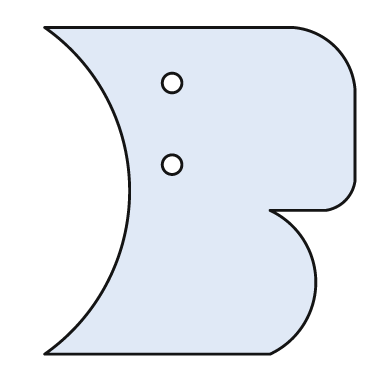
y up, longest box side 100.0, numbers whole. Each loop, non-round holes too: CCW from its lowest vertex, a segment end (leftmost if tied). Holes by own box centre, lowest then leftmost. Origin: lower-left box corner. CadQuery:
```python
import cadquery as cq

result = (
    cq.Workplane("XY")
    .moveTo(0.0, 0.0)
    .lineTo(69.0, 0.0)
    .threePointArc((83.0, 22.0), (69.0, 44.0))
    .lineTo(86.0, 44.0)
    .threePointArc((92.0, 47.0), (95.0, 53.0))
    .lineTo(95.0, 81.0)
    .threePointArc((89.0, 94.0), (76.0, 100.0))
    .lineTo(0.0, 100.0)
    .threePointArc((26.0, 50.0), (0.0, 0.0))
    .close()
    .moveTo(39.0, 58.0)
    .circle(3.0)
    .moveTo(39.0, 83.0)
    .circle(3.0)
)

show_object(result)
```